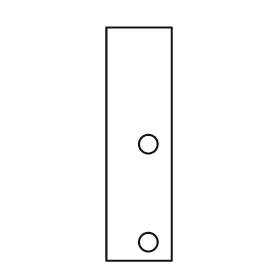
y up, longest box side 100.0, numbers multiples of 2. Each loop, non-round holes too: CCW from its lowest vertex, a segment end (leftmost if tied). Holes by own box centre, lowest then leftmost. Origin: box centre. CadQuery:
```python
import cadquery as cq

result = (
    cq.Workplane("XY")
    .moveTo(-14.0, -50.0)
    .lineTo(14.0, -50.0)
    .lineTo(14.0, 50.0)
    .lineTo(-14.0, 50.0)
    .close()
    .moveTo(4.0, -42.0)
    .circle(4.0)
    .moveTo(4.0, 0.0)
    .circle(4.0)
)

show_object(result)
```